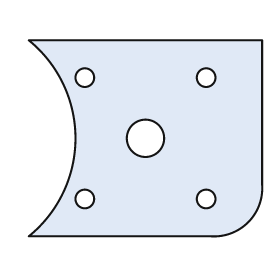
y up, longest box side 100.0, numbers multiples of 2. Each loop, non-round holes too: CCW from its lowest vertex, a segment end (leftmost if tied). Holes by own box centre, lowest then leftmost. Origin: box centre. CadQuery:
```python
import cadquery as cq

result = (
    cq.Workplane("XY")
    .moveTo(-50.0, -42.0)
    .lineTo(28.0, -42.0)
    .threePointArc((44.0, -36.0), (50.0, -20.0))
    .lineTo(50.0, 42.0)
    .lineTo(-50.0, 42.0)
    .threePointArc((-30.0, 0.0), (-50.0, -42.0))
    .close()
    .moveTo(-26.0, -26.0)
    .circle(4.0)
    .moveTo(26.0, -26.0)
    .circle(4.0)
    .moveTo(0.0, 0.0)
    .circle(8.0)
    .moveTo(-26.0, 26.0)
    .circle(4.0)
    .moveTo(26.0, 26.0)
    .circle(4.0)
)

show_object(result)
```